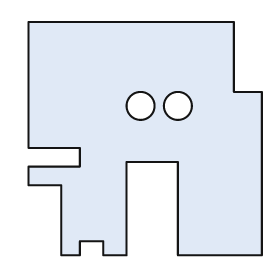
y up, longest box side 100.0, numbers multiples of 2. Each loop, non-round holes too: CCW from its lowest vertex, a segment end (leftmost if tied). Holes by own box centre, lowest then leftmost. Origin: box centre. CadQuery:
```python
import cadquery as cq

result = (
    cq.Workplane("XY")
    .moveTo(-36.0, -50.0)
    .lineTo(-28.0, -50.0)
    .lineTo(-28.0, -44.0)
    .lineTo(-18.0, -44.0)
    .lineTo(-18.0, -50.0)
    .lineTo(-8.0, -50.0)
    .lineTo(-8.0, -10.0)
    .lineTo(14.0, -10.0)
    .lineTo(14.0, -50.0)
    .lineTo(50.0, -50.0)
    .lineTo(50.0, 20.0)
    .lineTo(38.0, 20.0)
    .lineTo(38.0, 50.0)
    .lineTo(-50.0, 50.0)
    .lineTo(-50.0, -4.0)
    .lineTo(-28.0, -4.0)
    .lineTo(-28.0, -12.0)
    .lineTo(-50.0, -12.0)
    .lineTo(-50.0, -20.0)
    .lineTo(-36.0, -20.0)
    .close()
    .moveTo(-2.0, 14.0)
    .circle(6.0)
    .moveTo(14.0, 14.0)
    .circle(6.0)
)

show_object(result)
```